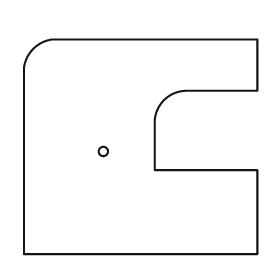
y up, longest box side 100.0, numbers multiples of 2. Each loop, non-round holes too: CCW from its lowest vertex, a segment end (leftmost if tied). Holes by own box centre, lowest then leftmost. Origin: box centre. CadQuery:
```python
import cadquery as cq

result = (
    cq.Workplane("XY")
    .moveTo(-50.0, -46.0)
    .lineTo(50.0, -46.0)
    .lineTo(50.0, -10.0)
    .lineTo(6.0, -10.0)
    .lineTo(6.0, 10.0)
    .threePointArc((10.0, 20.0), (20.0, 24.0))
    .lineTo(50.0, 24.0)
    .lineTo(50.0, 46.0)
    .lineTo(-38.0, 46.0)
    .threePointArc((-46.0, 42.0), (-50.0, 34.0))
    .close()
    .moveTo(-16.0, -2.0)
    .circle(2.0)
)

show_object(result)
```